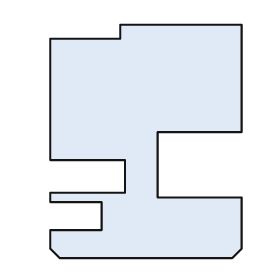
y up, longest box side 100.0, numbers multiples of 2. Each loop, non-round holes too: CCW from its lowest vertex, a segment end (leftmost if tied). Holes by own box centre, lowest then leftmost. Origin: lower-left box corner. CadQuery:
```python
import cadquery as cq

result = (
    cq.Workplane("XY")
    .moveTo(4.0, 0.0)
    .lineTo(78.0, 0.0)
    .lineTo(82.0, 4.0)
    .lineTo(82.0, 26.0)
    .lineTo(46.0, 26.0)
    .lineTo(46.0, 54.0)
    .lineTo(82.0, 54.0)
    .lineTo(82.0, 100.0)
    .lineTo(30.0, 100.0)
    .lineTo(30.0, 94.0)
    .lineTo(0.0, 94.0)
    .lineTo(0.0, 42.0)
    .lineTo(32.0, 42.0)
    .lineTo(32.0, 28.0)
    .lineTo(0.0, 28.0)
    .lineTo(0.0, 24.0)
    .lineTo(22.0, 24.0)
    .lineTo(22.0, 12.0)
    .lineTo(0.0, 12.0)
    .lineTo(0.0, 4.0)
    .close()
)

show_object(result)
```